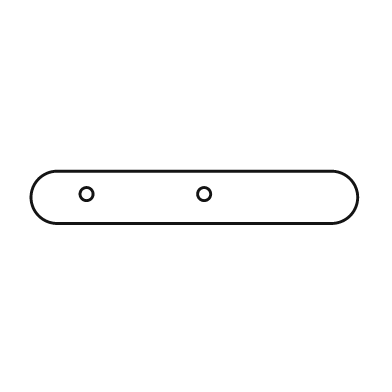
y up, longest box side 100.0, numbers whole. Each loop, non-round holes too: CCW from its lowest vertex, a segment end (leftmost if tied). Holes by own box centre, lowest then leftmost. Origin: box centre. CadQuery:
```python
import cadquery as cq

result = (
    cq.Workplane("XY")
    .moveTo(-42.0, -8.0)
    .lineTo(42.0, -8.0)
    .threePointArc((50.0, 0.0), (42.0, 8.0))
    .lineTo(-42.0, 8.0)
    .threePointArc((-50.0, 0.0), (-42.0, -8.0))
    .close()
    .moveTo(-33.0, 1.0)
    .circle(2.0)
    .moveTo(3.0, 1.0)
    .circle(2.0)
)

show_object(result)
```